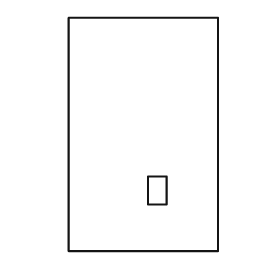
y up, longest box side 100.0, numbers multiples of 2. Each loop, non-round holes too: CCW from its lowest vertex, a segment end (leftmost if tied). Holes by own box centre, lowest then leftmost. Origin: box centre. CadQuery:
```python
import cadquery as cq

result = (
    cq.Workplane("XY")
    .moveTo(-32.0, -50.0)
    .lineTo(32.0, -50.0)
    .lineTo(32.0, 50.0)
    .lineTo(-32.0, 50.0)
    .close()
    .moveTo(2.0, -30.0)
    .lineTo(10.0, -30.0)
    .lineTo(10.0, -18.0)
    .lineTo(2.0, -18.0)
    .close()
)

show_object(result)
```